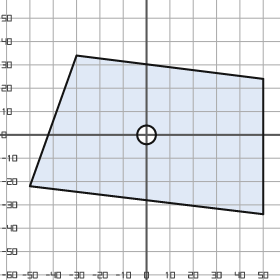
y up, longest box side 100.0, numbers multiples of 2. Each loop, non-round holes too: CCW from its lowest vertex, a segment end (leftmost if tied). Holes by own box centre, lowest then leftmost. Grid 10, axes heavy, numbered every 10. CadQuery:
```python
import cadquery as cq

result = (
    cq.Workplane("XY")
    .moveTo(50.0, -34.0)
    .lineTo(50.0, 24.0)
    .lineTo(-30.0, 34.0)
    .lineTo(-50.0, -22.0)
    .close()
    .moveTo(0.0, 0.0)
    .circle(4.0)
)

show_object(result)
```